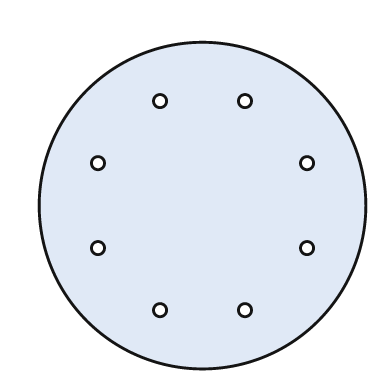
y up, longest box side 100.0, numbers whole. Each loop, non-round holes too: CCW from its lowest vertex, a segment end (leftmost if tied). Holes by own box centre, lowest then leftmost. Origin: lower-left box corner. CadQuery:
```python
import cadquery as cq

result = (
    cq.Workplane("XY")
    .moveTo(50.0, 50.0)
    .circle(50.0)
    .moveTo(37.0, 18.0)
    .circle(2.0)
    .moveTo(63.0, 18.0)
    .circle(2.0)
    .moveTo(18.0, 37.0)
    .circle(2.0)
    .moveTo(82.0, 37.0)
    .circle(2.0)
    .moveTo(18.0, 63.0)
    .circle(2.0)
    .moveTo(82.0, 63.0)
    .circle(2.0)
    .moveTo(37.0, 82.0)
    .circle(2.0)
    .moveTo(63.0, 82.0)
    .circle(2.0)
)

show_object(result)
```